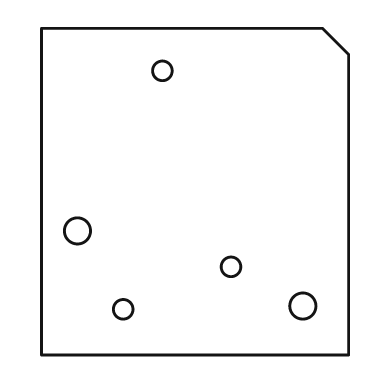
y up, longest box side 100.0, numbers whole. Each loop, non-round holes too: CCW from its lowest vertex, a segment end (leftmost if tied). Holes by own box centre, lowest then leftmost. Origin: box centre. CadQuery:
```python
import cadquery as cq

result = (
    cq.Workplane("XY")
    .moveTo(-47.0, -50.0)
    .lineTo(47.0, -50.0)
    .lineTo(47.0, 42.0)
    .lineTo(39.0, 50.0)
    .lineTo(-47.0, 50.0)
    .close()
    .moveTo(-22.0, -36.0)
    .circle(3.0)
    .moveTo(33.0, -35.0)
    .circle(4.0)
    .moveTo(11.0, -23.0)
    .circle(3.0)
    .moveTo(-36.0, -12.0)
    .circle(4.0)
    .moveTo(-10.0, 37.0)
    .circle(3.0)
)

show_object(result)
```